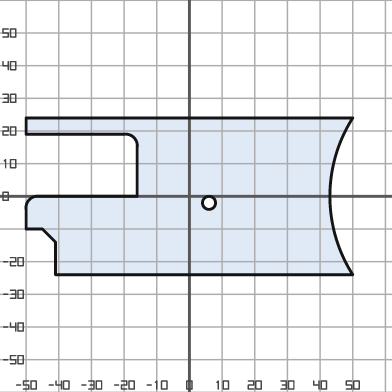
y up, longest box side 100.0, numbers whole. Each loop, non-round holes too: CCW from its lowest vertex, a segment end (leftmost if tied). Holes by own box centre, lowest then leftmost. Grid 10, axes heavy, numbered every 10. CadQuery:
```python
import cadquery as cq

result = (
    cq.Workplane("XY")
    .moveTo(-41.0, -24.0)
    .lineTo(50.0, -24.0)
    .threePointArc((43.0, 0.0), (50.0, 24.0))
    .lineTo(-50.0, 24.0)
    .lineTo(-50.0, 19.0)
    .lineTo(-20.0, 19.0)
    .threePointArc((-17.0, 18.0), (-16.0, 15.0))
    .lineTo(-16.0, 0.0)
    .lineTo(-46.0, 0.0)
    .threePointArc((-49.0, -1.0), (-50.0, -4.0))
    .lineTo(-50.0, -10.0)
    .lineTo(-45.0, -10.0)
    .lineTo(-41.0, -14.0)
    .close()
    .moveTo(6.0, -2.0)
    .circle(2.0)
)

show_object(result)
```